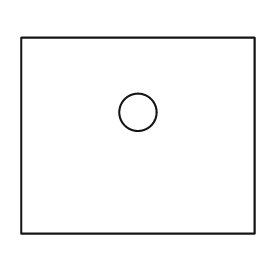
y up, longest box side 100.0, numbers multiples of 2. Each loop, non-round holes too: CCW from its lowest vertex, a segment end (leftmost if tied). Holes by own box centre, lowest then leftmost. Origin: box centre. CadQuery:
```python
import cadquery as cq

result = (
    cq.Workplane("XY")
    .moveTo(-50.0, -42.0)
    .lineTo(50.0, -42.0)
    .lineTo(50.0, 42.0)
    .lineTo(-50.0, 42.0)
    .close()
    .moveTo(0.0, 10.0)
    .circle(8.0)
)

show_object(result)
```